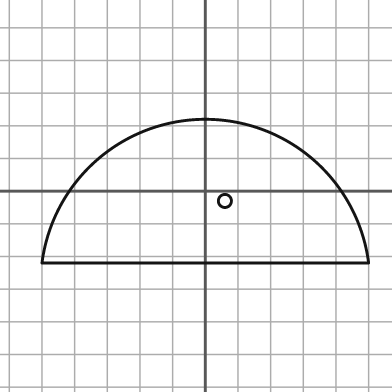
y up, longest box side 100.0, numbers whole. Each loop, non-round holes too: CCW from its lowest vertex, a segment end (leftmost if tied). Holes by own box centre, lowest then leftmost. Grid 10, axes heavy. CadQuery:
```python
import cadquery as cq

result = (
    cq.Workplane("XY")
    .moveTo(-50.0, -22.0)
    .lineTo(50.0, -22.0)
    .threePointArc((0.0, 22.0), (-50.0, -22.0))
    .close()
    .moveTo(6.0, -3.0)
    .circle(2.0)
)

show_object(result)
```